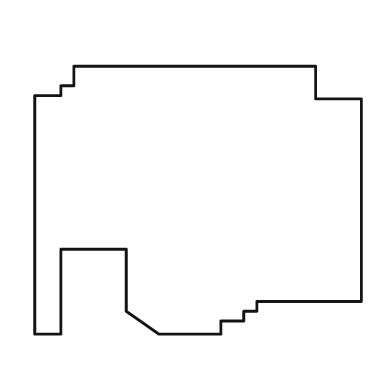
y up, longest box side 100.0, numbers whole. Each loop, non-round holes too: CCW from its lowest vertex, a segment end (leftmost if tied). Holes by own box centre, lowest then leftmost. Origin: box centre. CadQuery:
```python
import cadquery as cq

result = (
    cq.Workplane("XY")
    .moveTo(-50.0, -41.0)
    .lineTo(-42.0, -41.0)
    .lineTo(-42.0, -15.0)
    .lineTo(-22.0, -15.0)
    .lineTo(-22.0, -34.0)
    .lineTo(-12.0, -41.0)
    .lineTo(7.0, -41.0)
    .lineTo(7.0, -37.0)
    .lineTo(14.0, -37.0)
    .lineTo(14.0, -34.0)
    .lineTo(18.0, -34.0)
    .lineTo(18.0, -31.0)
    .lineTo(50.0, -31.0)
    .lineTo(50.0, 31.0)
    .lineTo(36.0, 31.0)
    .lineTo(36.0, 41.0)
    .lineTo(-38.0, 41.0)
    .lineTo(-38.0, 35.0)
    .lineTo(-42.0, 35.0)
    .lineTo(-42.0, 32.0)
    .lineTo(-50.0, 32.0)
    .close()
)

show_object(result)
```